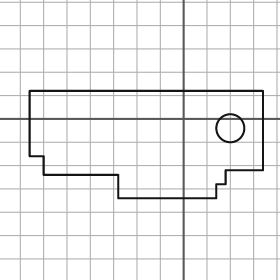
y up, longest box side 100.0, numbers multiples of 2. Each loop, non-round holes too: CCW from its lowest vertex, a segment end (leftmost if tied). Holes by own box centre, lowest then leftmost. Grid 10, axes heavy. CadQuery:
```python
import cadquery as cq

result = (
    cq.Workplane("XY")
    .moveTo(-28.0, -34.0)
    .lineTo(14.0, -34.0)
    .lineTo(14.0, -28.0)
    .lineTo(18.0, -28.0)
    .lineTo(18.0, -22.0)
    .lineTo(34.0, -22.0)
    .lineTo(34.0, 12.0)
    .lineTo(-66.0, 12.0)
    .lineTo(-66.0, -16.0)
    .lineTo(-60.0, -16.0)
    .lineTo(-60.0, -24.0)
    .lineTo(-28.0, -24.0)
    .close()
    .moveTo(20.0, -4.0)
    .circle(6.0)
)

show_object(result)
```